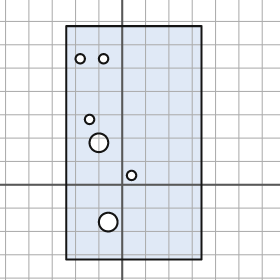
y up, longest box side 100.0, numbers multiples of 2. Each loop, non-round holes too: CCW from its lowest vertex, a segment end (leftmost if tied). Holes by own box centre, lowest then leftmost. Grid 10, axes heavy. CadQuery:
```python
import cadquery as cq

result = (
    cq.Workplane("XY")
    .moveTo(-24.0, -32.0)
    .lineTo(34.0, -32.0)
    .lineTo(34.0, 68.0)
    .lineTo(-24.0, 68.0)
    .close()
    .moveTo(-6.0, -16.0)
    .circle(4.0)
    .moveTo(4.0, 4.0)
    .circle(2.0)
    .moveTo(-10.0, 18.0)
    .circle(4.0)
    .moveTo(-14.0, 28.0)
    .circle(2.0)
    .moveTo(-18.0, 54.0)
    .circle(2.0)
    .moveTo(-8.0, 54.0)
    .circle(2.0)
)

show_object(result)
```